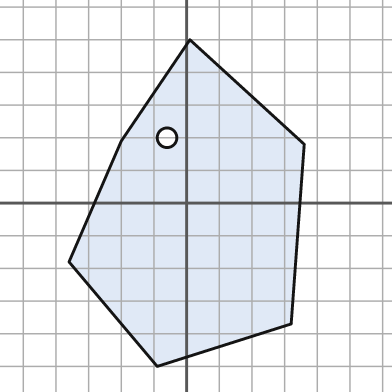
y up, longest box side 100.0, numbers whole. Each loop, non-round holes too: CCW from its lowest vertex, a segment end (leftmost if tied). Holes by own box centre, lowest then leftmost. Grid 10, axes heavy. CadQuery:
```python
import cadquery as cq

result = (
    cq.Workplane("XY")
    .moveTo(-9.0, -50.0)
    .lineTo(32.0, -37.0)
    .lineTo(36.0, 18.0)
    .lineTo(1.0, 50.0)
    .lineTo(-20.0, 19.0)
    .lineTo(-36.0, -18.0)
    .close()
    .moveTo(-6.0, 20.0)
    .circle(3.0)
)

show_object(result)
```